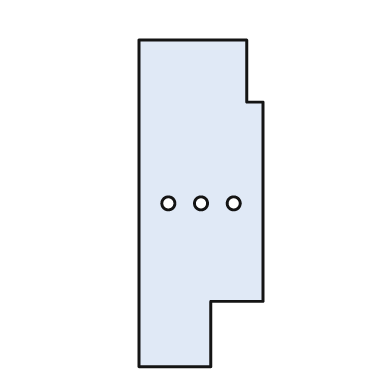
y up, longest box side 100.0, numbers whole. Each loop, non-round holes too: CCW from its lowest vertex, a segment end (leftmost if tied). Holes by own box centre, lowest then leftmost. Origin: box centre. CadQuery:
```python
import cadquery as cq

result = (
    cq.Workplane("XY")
    .moveTo(-19.0, -50.0)
    .lineTo(3.0, -50.0)
    .lineTo(3.0, -30.0)
    .lineTo(19.0, -30.0)
    .lineTo(19.0, 31.0)
    .lineTo(14.0, 31.0)
    .lineTo(14.0, 50.0)
    .lineTo(-19.0, 50.0)
    .close()
    .moveTo(-10.0, 0.0)
    .circle(2.0)
    .moveTo(0.0, 0.0)
    .circle(2.0)
    .moveTo(10.0, 0.0)
    .circle(2.0)
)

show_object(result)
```